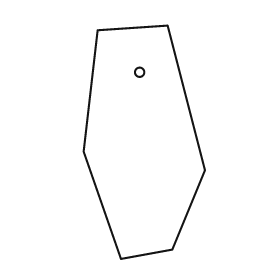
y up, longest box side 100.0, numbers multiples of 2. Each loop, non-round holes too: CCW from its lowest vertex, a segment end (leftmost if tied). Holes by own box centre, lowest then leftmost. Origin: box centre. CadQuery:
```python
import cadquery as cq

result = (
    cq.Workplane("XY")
    .moveTo(-10.0, -50.0)
    .lineTo(12.0, -46.0)
    .lineTo(26.0, -12.0)
    .lineTo(10.0, 50.0)
    .lineTo(-20.0, 48.0)
    .lineTo(-26.0, -4.0)
    .close()
    .moveTo(-2.0, 30.0)
    .circle(2.0)
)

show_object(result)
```